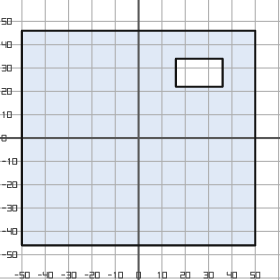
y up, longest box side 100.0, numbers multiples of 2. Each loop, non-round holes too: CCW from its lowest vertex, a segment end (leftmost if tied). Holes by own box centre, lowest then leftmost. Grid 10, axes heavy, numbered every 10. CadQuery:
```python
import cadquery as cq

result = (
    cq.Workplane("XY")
    .moveTo(-50.0, -46.0)
    .lineTo(50.0, -46.0)
    .lineTo(50.0, 46.0)
    .lineTo(-50.0, 46.0)
    .close()
    .moveTo(16.0, 22.0)
    .lineTo(36.0, 22.0)
    .lineTo(36.0, 34.0)
    .lineTo(16.0, 34.0)
    .close()
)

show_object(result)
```